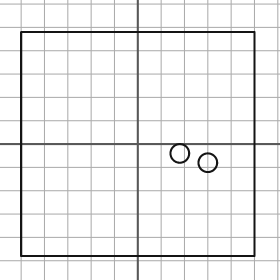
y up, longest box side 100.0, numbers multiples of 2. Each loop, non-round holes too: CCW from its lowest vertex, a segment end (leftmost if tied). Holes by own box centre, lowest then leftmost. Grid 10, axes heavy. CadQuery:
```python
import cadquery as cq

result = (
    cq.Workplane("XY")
    .moveTo(-50.0, -48.0)
    .lineTo(50.0, -48.0)
    .lineTo(50.0, 48.0)
    .lineTo(-50.0, 48.0)
    .close()
    .moveTo(30.0, -8.0)
    .circle(4.0)
    .moveTo(18.0, -4.0)
    .circle(4.0)
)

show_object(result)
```